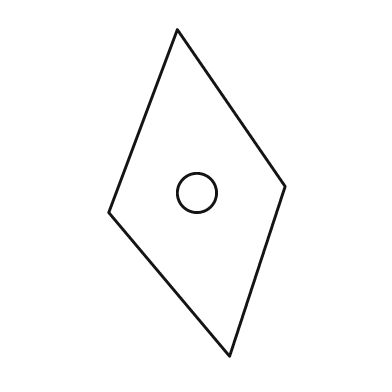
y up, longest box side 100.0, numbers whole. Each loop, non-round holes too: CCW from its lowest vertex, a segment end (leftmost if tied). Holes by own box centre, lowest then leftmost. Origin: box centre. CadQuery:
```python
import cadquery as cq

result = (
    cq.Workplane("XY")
    .moveTo(10.0, -50.0)
    .lineTo(27.0, 2.0)
    .lineTo(-6.0, 50.0)
    .lineTo(-27.0, -6.0)
    .close()
    .moveTo(0.0, 0.0)
    .circle(6.0)
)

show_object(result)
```